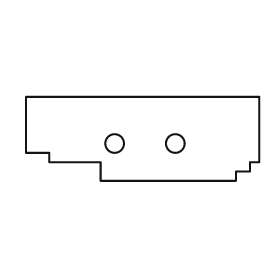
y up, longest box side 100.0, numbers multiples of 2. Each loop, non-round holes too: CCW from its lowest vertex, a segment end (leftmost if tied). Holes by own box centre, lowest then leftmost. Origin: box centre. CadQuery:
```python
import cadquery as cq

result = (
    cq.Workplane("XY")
    .moveTo(-18.0, -18.0)
    .lineTo(40.0, -18.0)
    .lineTo(40.0, -14.0)
    .lineTo(46.0, -14.0)
    .lineTo(46.0, -10.0)
    .lineTo(50.0, -10.0)
    .lineTo(50.0, 18.0)
    .lineTo(-50.0, 18.0)
    .lineTo(-50.0, -6.0)
    .lineTo(-40.0, -6.0)
    .lineTo(-40.0, -10.0)
    .lineTo(-18.0, -10.0)
    .close()
    .moveTo(-12.0, -2.0)
    .circle(4.0)
    .moveTo(14.0, -2.0)
    .circle(4.0)
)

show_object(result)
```